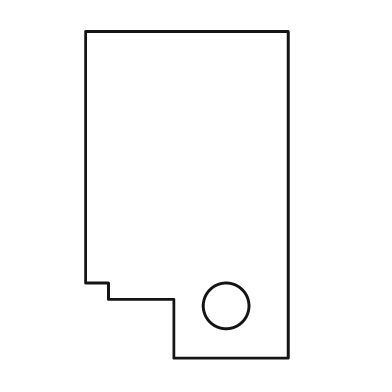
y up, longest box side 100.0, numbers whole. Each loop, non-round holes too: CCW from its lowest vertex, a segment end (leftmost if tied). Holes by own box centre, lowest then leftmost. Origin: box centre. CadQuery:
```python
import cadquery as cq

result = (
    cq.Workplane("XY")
    .moveTo(-4.0, -50.0)
    .lineTo(31.0, -50.0)
    .lineTo(31.0, 50.0)
    .lineTo(-31.0, 50.0)
    .lineTo(-31.0, -27.0)
    .lineTo(-24.0, -27.0)
    .lineTo(-24.0, -32.0)
    .lineTo(-4.0, -32.0)
    .close()
    .moveTo(12.0, -34.0)
    .circle(7.0)
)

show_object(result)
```